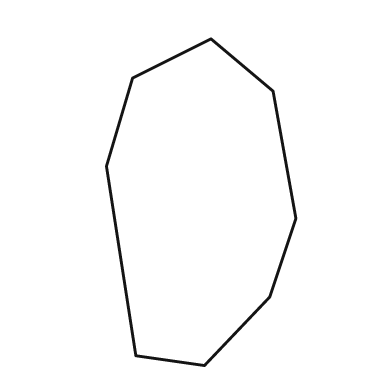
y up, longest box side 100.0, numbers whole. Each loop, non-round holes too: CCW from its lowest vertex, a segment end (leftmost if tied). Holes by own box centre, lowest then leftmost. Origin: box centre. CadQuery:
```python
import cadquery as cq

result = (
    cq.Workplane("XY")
    .moveTo(1.0, -50.0)
    .lineTo(21.0, -29.0)
    .lineTo(29.0, -5.0)
    .lineTo(22.0, 34.0)
    .lineTo(3.0, 50.0)
    .lineTo(-21.0, 38.0)
    .lineTo(-29.0, 11.0)
    .lineTo(-20.0, -47.0)
    .close()
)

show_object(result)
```